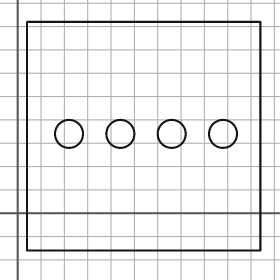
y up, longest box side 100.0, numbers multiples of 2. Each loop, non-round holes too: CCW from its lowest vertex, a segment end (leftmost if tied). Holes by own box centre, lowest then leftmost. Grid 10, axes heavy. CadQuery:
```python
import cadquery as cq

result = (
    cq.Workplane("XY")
    .moveTo(4.0, -16.0)
    .lineTo(104.0, -16.0)
    .lineTo(104.0, 82.0)
    .lineTo(4.0, 82.0)
    .close()
    .moveTo(22.0, 34.0)
    .circle(6.0)
    .moveTo(44.0, 34.0)
    .circle(6.0)
    .moveTo(66.0, 34.0)
    .circle(6.0)
    .moveTo(88.0, 34.0)
    .circle(6.0)
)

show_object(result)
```